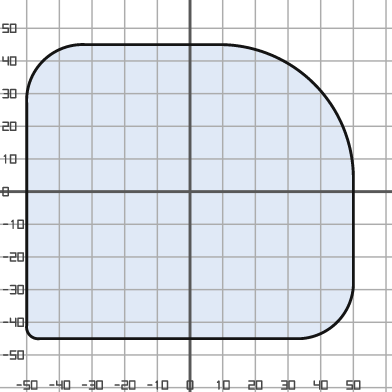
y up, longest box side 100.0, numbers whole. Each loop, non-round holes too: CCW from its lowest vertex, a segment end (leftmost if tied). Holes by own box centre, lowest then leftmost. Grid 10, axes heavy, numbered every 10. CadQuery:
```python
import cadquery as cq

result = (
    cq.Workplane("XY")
    .moveTo(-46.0, -45.0)
    .lineTo(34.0, -45.0)
    .threePointArc((45.0, -40.0), (50.0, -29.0))
    .lineTo(50.0, 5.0)
    .threePointArc((38.0, 33.0), (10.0, 45.0))
    .lineTo(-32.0, 45.0)
    .threePointArc((-45.0, 40.0), (-50.0, 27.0))
    .lineTo(-50.0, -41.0)
    .threePointArc((-49.0, -44.0), (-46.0, -45.0))
    .close()
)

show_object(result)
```